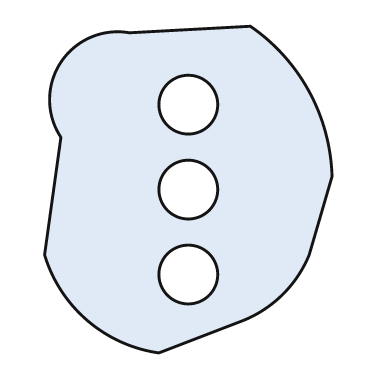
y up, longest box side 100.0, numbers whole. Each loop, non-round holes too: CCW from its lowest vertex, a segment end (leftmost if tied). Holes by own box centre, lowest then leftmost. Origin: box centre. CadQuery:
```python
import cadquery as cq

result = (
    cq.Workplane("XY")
    .moveTo(-9.0, -50.0)
    .lineTo(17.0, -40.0)
    .threePointArc((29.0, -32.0), (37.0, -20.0))
    .lineTo(44.0, 4.0)
    .threePointArc((37.0, 30.0), (19.0, 50.0))
    .lineTo(-18.0, 48.0)
    .threePointArc((-39.0, 39.0), (-39.0, 16.0))
    .lineTo(-44.0, -20.0)
    .threePointArc((-31.0, -40.0), (-9.0, -50.0))
    .close()
    .moveTo(0.0, -26.0)
    .circle(9.0)
    .moveTo(0.0, 0.0)
    .circle(9.0)
    .moveTo(0.0, 26.0)
    .circle(9.0)
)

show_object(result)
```